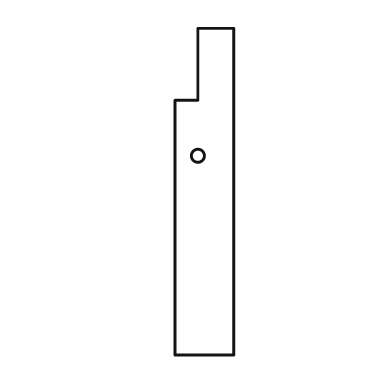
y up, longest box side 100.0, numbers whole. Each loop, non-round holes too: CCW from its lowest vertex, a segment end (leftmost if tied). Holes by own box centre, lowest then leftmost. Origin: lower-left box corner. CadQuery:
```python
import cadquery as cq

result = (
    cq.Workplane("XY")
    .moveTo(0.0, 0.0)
    .lineTo(18.0, 0.0)
    .lineTo(18.0, 100.0)
    .lineTo(7.0, 100.0)
    .lineTo(7.0, 78.0)
    .lineTo(0.0, 78.0)
    .close()
    .moveTo(7.0, 61.0)
    .circle(2.0)
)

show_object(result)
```